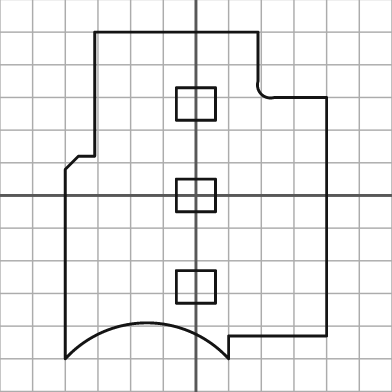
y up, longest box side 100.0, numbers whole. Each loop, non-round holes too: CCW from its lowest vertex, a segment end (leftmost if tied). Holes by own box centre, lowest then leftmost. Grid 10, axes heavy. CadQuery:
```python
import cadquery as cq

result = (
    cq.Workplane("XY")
    .moveTo(-40.0, -50.0)
    .threePointArc((-15.0, -39.0), (10.0, -50.0))
    .lineTo(10.0, -43.0)
    .lineTo(40.0, -43.0)
    .lineTo(40.0, 30.0)
    .lineTo(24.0, 30.0)
    .threePointArc((20.0, 31.0), (19.0, 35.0))
    .lineTo(19.0, 50.0)
    .lineTo(-31.0, 50.0)
    .lineTo(-31.0, 12.0)
    .lineTo(-36.0, 12.0)
    .lineTo(-40.0, 8.0)
    .close()
    .moveTo(-6.0, -33.0)
    .lineTo(6.0, -33.0)
    .lineTo(6.0, -23.0)
    .lineTo(-6.0, -23.0)
    .close()
    .moveTo(-6.0, -5.0)
    .lineTo(6.0, -5.0)
    .lineTo(6.0, 5.0)
    .lineTo(-6.0, 5.0)
    .close()
    .moveTo(-6.0, 23.0)
    .lineTo(6.0, 23.0)
    .lineTo(6.0, 33.0)
    .lineTo(-6.0, 33.0)
    .close()
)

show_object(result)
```